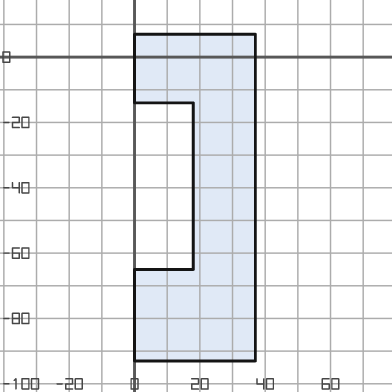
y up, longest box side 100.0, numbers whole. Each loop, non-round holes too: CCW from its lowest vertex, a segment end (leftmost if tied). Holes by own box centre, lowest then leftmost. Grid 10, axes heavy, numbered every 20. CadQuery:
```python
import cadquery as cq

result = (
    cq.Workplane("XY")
    .moveTo(0.0, -93.0)
    .lineTo(37.0, -93.0)
    .lineTo(37.0, 7.0)
    .lineTo(0.0, 7.0)
    .lineTo(0.0, -14.0)
    .lineTo(18.0, -14.0)
    .lineTo(18.0, -65.0)
    .lineTo(0.0, -65.0)
    .close()
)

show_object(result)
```